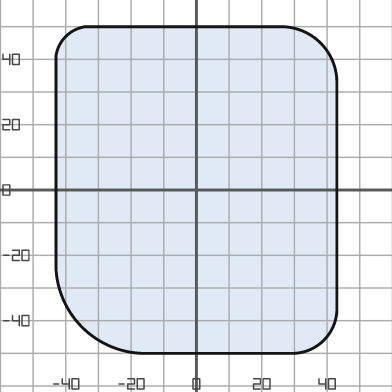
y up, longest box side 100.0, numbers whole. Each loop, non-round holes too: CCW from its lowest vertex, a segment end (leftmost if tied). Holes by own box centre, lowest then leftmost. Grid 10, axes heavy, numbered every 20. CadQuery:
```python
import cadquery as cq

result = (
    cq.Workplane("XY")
    .moveTo(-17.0, -50.0)
    .lineTo(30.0, -50.0)
    .threePointArc((39.0, -46.0), (43.0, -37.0))
    .lineTo(43.0, 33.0)
    .threePointArc((38.0, 45.0), (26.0, 50.0))
    .lineTo(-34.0, 50.0)
    .threePointArc((-40.0, 47.0), (-43.0, 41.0))
    .lineTo(-43.0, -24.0)
    .threePointArc((-35.0, -42.0), (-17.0, -50.0))
    .close()
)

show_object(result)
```